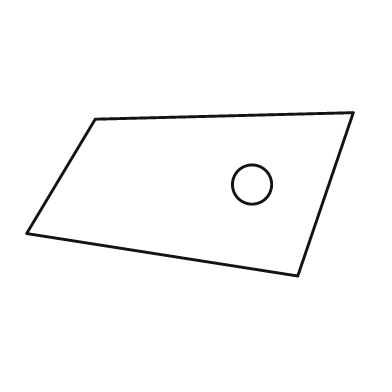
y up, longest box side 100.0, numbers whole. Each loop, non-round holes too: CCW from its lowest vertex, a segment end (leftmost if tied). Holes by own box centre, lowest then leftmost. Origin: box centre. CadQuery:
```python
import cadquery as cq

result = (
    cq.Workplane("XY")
    .moveTo(33.0, -25.0)
    .lineTo(50.0, 25.0)
    .lineTo(-29.0, 23.0)
    .lineTo(-50.0, -12.0)
    .close()
    .moveTo(19.0, 3.0)
    .circle(6.0)
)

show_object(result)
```